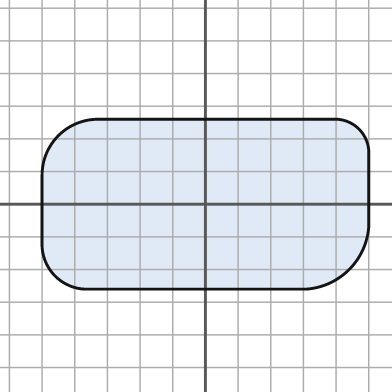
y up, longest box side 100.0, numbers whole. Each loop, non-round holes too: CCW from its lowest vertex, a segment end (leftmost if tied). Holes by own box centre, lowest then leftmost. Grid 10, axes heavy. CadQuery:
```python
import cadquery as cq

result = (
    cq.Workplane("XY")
    .moveTo(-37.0, -26.0)
    .lineTo(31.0, -26.0)
    .threePointArc((44.0, -20.0), (50.0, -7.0))
    .lineTo(50.0, 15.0)
    .threePointArc((47.0, 23.0), (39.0, 26.0))
    .lineTo(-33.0, 26.0)
    .threePointArc((-45.0, 21.0), (-50.0, 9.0))
    .lineTo(-50.0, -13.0)
    .threePointArc((-46.0, -22.0), (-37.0, -26.0))
    .close()
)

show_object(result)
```